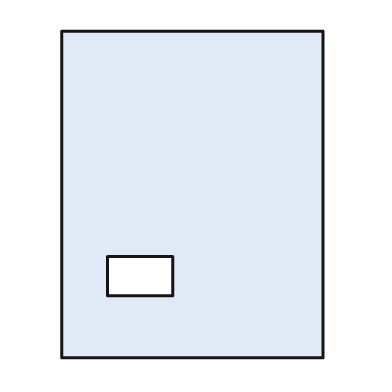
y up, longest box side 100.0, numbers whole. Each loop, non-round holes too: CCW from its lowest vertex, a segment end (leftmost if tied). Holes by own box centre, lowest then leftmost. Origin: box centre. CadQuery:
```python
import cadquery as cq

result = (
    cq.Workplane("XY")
    .moveTo(-40.0, -50.0)
    .lineTo(40.0, -50.0)
    .lineTo(40.0, 50.0)
    .lineTo(-40.0, 50.0)
    .close()
    .moveTo(-26.0, -31.0)
    .lineTo(-6.0, -31.0)
    .lineTo(-6.0, -19.0)
    .lineTo(-26.0, -19.0)
    .close()
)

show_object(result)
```